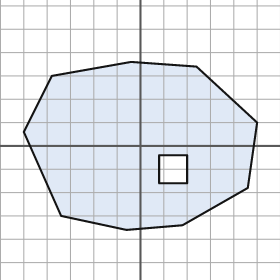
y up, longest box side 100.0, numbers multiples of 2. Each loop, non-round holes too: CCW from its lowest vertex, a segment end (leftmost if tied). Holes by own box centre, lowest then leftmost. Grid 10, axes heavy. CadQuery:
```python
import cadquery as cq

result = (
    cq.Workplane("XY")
    .moveTo(-6.0, -36.0)
    .lineTo(18.0, -34.0)
    .lineTo(46.0, -18.0)
    .lineTo(50.0, 10.0)
    .lineTo(24.0, 34.0)
    .lineTo(-4.0, 36.0)
    .lineTo(-38.0, 30.0)
    .lineTo(-50.0, 6.0)
    .lineTo(-34.0, -30.0)
    .close()
    .moveTo(8.0, -16.0)
    .lineTo(20.0, -16.0)
    .lineTo(20.0, -4.0)
    .lineTo(8.0, -4.0)
    .close()
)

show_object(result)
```